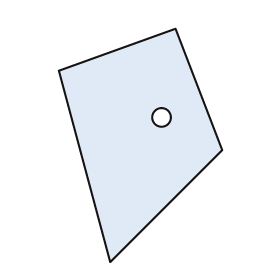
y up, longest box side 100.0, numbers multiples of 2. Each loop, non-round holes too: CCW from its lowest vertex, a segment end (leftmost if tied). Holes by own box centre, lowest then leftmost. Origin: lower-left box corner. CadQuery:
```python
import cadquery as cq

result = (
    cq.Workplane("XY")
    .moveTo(22.0, 0.0)
    .lineTo(70.0, 48.0)
    .lineTo(50.0, 100.0)
    .lineTo(0.0, 82.0)
    .close()
    .moveTo(44.0, 62.0)
    .circle(4.0)
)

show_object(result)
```